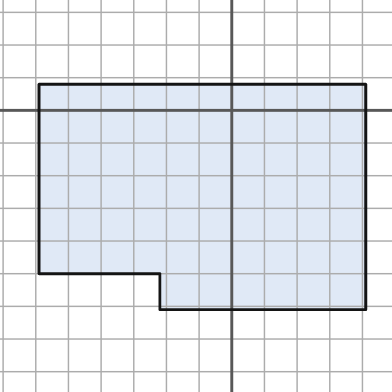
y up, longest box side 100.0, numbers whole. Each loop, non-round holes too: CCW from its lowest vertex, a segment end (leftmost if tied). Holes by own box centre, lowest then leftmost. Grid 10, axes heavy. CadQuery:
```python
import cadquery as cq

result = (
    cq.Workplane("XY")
    .moveTo(-22.0, -61.0)
    .lineTo(41.0, -61.0)
    .lineTo(41.0, 8.0)
    .lineTo(-59.0, 8.0)
    .lineTo(-59.0, -50.0)
    .lineTo(-22.0, -50.0)
    .close()
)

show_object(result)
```